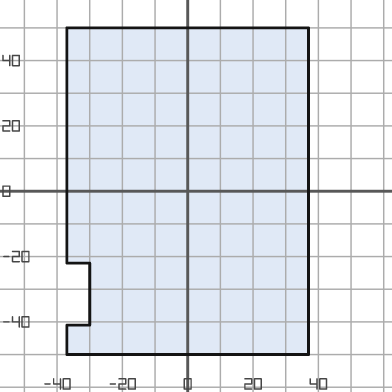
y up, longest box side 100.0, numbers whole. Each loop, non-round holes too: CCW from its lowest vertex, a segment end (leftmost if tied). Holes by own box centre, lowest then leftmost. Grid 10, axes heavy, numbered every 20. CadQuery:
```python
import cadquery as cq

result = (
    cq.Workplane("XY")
    .moveTo(-37.0, -50.0)
    .lineTo(37.0, -50.0)
    .lineTo(37.0, 50.0)
    .lineTo(-37.0, 50.0)
    .lineTo(-37.0, -22.0)
    .lineTo(-30.0, -22.0)
    .lineTo(-30.0, -41.0)
    .lineTo(-37.0, -41.0)
    .close()
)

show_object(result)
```